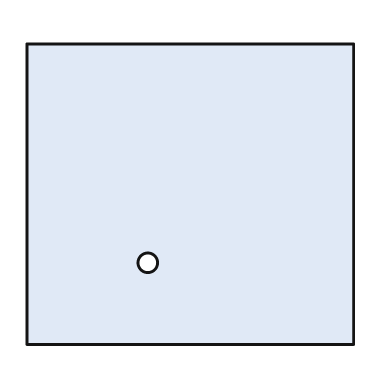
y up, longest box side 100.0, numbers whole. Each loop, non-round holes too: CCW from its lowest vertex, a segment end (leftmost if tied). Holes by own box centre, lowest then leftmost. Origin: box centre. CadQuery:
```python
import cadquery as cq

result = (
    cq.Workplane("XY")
    .moveTo(-50.0, -46.0)
    .lineTo(50.0, -46.0)
    .lineTo(50.0, 46.0)
    .lineTo(-50.0, 46.0)
    .close()
    .moveTo(-13.0, -21.0)
    .circle(3.0)
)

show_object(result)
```